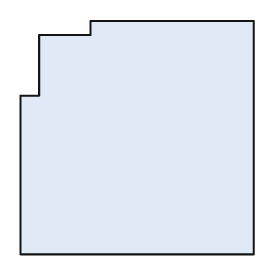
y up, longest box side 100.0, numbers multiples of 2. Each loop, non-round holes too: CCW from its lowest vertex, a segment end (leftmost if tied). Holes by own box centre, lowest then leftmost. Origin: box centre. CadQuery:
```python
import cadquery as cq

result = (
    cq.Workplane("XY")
    .moveTo(-50.0, -50.0)
    .lineTo(50.0, -50.0)
    .lineTo(50.0, 50.0)
    .lineTo(-20.0, 50.0)
    .lineTo(-20.0, 44.0)
    .lineTo(-42.0, 44.0)
    .lineTo(-42.0, 18.0)
    .lineTo(-50.0, 18.0)
    .close()
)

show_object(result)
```